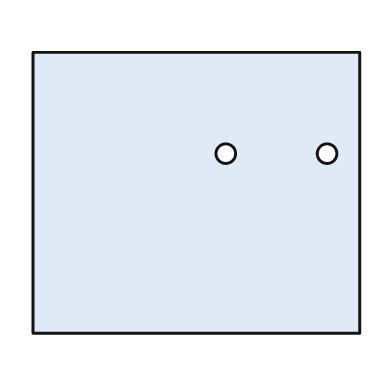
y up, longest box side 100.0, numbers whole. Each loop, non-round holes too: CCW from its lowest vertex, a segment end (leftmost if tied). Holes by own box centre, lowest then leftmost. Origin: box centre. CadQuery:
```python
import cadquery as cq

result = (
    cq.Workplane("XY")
    .moveTo(-50.0, -43.0)
    .lineTo(50.0, -43.0)
    .lineTo(50.0, 43.0)
    .lineTo(-50.0, 43.0)
    .close()
    .moveTo(9.0, 12.0)
    .circle(3.0)
    .moveTo(40.0, 12.0)
    .circle(3.0)
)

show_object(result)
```